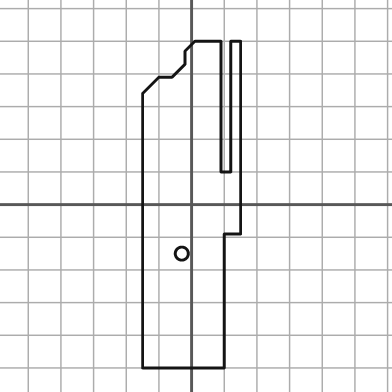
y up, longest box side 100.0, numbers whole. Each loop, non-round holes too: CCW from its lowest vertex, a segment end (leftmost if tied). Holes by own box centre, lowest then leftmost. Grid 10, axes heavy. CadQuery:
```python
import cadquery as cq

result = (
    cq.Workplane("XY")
    .moveTo(-15.0, -50.0)
    .lineTo(10.0, -50.0)
    .lineTo(10.0, -9.0)
    .lineTo(15.0, -9.0)
    .lineTo(15.0, 50.0)
    .lineTo(12.0, 50.0)
    .lineTo(12.0, 10.0)
    .lineTo(9.0, 10.0)
    .lineTo(9.0, 50.0)
    .lineTo(1.0, 50.0)
    .lineTo(-2.0, 47.0)
    .lineTo(-2.0, 43.0)
    .lineTo(-6.0, 39.0)
    .lineTo(-10.0, 39.0)
    .lineTo(-15.0, 34.0)
    .close()
    .moveTo(-3.0, -15.0)
    .circle(2.0)
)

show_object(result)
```